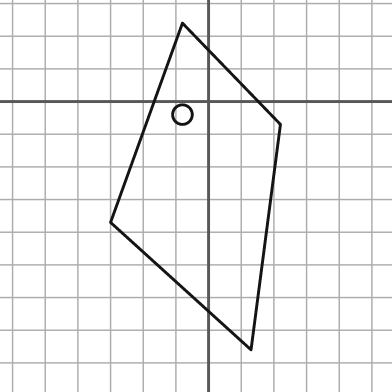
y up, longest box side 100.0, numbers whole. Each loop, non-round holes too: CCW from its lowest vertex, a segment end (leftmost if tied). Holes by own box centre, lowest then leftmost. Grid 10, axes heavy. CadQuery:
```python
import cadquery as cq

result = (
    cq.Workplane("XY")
    .moveTo(13.0, -76.0)
    .lineTo(22.0, -7.0)
    .lineTo(-8.0, 24.0)
    .lineTo(-30.0, -37.0)
    .close()
    .moveTo(-8.0, -4.0)
    .circle(3.0)
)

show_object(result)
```